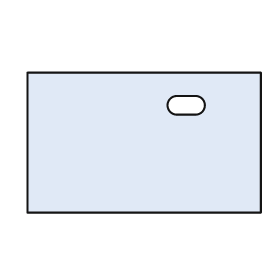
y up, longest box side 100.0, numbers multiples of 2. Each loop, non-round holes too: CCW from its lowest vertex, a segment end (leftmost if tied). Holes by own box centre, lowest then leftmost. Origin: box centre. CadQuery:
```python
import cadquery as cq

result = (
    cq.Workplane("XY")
    .moveTo(-50.0, -30.0)
    .lineTo(50.0, -30.0)
    .lineTo(50.0, 30.0)
    .lineTo(-50.0, 30.0)
    .close()
    .moveTo(14.0, 12.0)
    .lineTo(22.0, 12.0)
    .threePointArc((26.0, 16.0), (22.0, 20.0))
    .lineTo(14.0, 20.0)
    .threePointArc((10.0, 16.0), (14.0, 12.0))
    .close()
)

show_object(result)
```